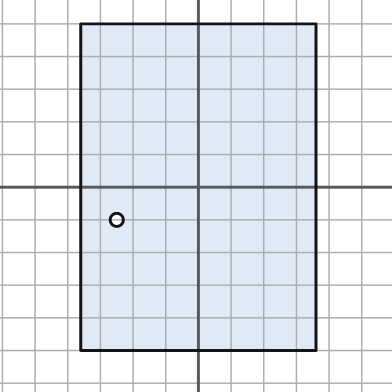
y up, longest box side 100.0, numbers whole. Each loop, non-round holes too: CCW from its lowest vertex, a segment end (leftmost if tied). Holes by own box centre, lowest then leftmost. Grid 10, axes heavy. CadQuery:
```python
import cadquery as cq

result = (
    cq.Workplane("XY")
    .moveTo(-36.0, -50.0)
    .lineTo(36.0, -50.0)
    .lineTo(36.0, 50.0)
    .lineTo(-36.0, 50.0)
    .close()
    .moveTo(-25.0, -10.0)
    .circle(2.0)
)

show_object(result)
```